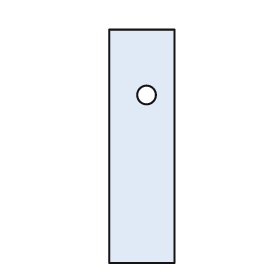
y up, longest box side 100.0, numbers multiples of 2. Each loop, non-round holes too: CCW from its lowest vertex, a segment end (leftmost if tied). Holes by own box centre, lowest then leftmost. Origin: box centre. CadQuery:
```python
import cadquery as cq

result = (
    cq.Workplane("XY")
    .moveTo(-14.0, -50.0)
    .lineTo(14.0, -50.0)
    .lineTo(14.0, 50.0)
    .lineTo(-14.0, 50.0)
    .close()
    .moveTo(2.0, 22.0)
    .circle(4.0)
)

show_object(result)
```